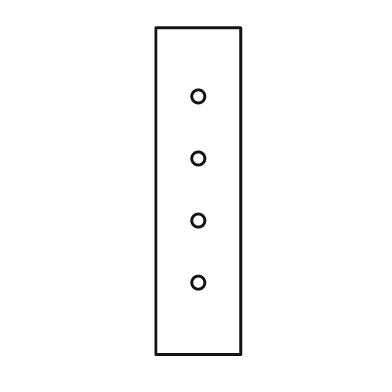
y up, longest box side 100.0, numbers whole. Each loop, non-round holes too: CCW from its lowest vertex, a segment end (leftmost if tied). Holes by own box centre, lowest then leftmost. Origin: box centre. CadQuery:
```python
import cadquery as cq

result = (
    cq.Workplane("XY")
    .moveTo(-13.0, -50.0)
    .lineTo(13.0, -50.0)
    .lineTo(13.0, 50.0)
    .lineTo(-13.0, 50.0)
    .close()
    .moveTo(0.0, -28.0)
    .circle(2.0)
    .moveTo(0.0, -9.0)
    .circle(2.0)
    .moveTo(0.0, 10.0)
    .circle(2.0)
    .moveTo(0.0, 29.0)
    .circle(2.0)
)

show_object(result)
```